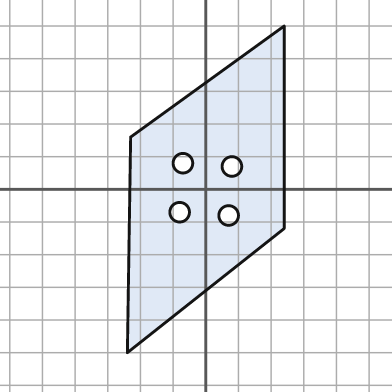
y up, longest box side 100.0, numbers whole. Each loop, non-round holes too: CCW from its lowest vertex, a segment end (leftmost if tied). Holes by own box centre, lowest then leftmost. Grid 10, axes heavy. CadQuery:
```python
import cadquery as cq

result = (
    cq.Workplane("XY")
    .moveTo(-24.0, -50.0)
    .lineTo(24.0, -12.0)
    .lineTo(24.0, 50.0)
    .lineTo(-23.0, 16.0)
    .close()
    .moveTo(7.0, -8.0)
    .circle(3.0)
    .moveTo(-8.0, -7.0)
    .circle(3.0)
    .moveTo(8.0, 7.0)
    .circle(3.0)
    .moveTo(-7.0, 8.0)
    .circle(3.0)
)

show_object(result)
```